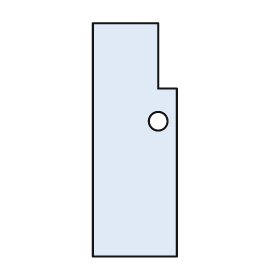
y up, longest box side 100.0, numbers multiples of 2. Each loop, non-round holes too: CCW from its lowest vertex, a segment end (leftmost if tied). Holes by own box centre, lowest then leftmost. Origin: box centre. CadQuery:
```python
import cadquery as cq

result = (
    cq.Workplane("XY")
    .moveTo(-18.0, -50.0)
    .lineTo(18.0, -50.0)
    .lineTo(18.0, 22.0)
    .lineTo(10.0, 22.0)
    .lineTo(10.0, 50.0)
    .lineTo(-18.0, 50.0)
    .close()
    .moveTo(10.0, 8.0)
    .circle(4.0)
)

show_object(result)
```